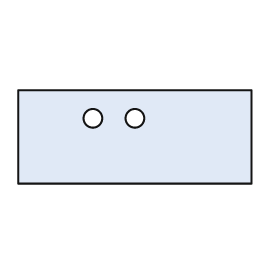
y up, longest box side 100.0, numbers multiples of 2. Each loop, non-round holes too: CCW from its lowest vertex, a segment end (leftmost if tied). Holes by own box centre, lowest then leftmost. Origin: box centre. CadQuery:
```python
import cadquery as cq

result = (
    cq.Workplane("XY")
    .moveTo(-50.0, -20.0)
    .lineTo(50.0, -20.0)
    .lineTo(50.0, 20.0)
    .lineTo(-50.0, 20.0)
    .close()
    .moveTo(-18.0, 8.0)
    .circle(4.0)
    .moveTo(0.0, 8.0)
    .circle(4.0)
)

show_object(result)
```